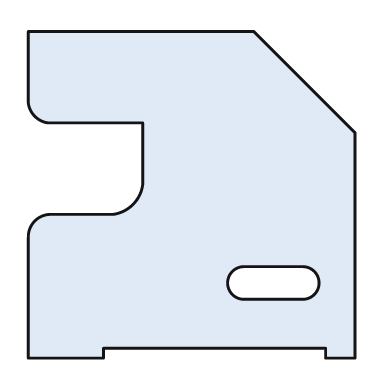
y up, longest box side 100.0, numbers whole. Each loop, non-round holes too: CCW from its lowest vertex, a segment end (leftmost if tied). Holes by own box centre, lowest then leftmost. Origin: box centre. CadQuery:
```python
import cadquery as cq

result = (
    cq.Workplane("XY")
    .moveTo(-50.0, -50.0)
    .lineTo(-27.0, -50.0)
    .lineTo(-27.0, -47.0)
    .lineTo(41.0, -47.0)
    .lineTo(41.0, -50.0)
    .lineTo(50.0, -50.0)
    .lineTo(50.0, 19.0)
    .lineTo(19.0, 50.0)
    .lineTo(-50.0, 50.0)
    .lineTo(-50.0, 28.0)
    .threePointArc((-48.0, 24.0), (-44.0, 22.0))
    .lineTo(-15.0, 22.0)
    .lineTo(-15.0, 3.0)
    .threePointArc((-18.0, -3.0), (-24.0, -6.0))
    .lineTo(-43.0, -6.0)
    .threePointArc((-48.0, -8.0), (-50.0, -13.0))
    .close()
    .moveTo(16.0, -32.0)
    .lineTo(34.0, -32.0)
    .threePointArc((39.0, -27.0), (34.0, -22.0))
    .lineTo(16.0, -22.0)
    .threePointArc((11.0, -27.0), (16.0, -32.0))
    .close()
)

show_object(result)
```